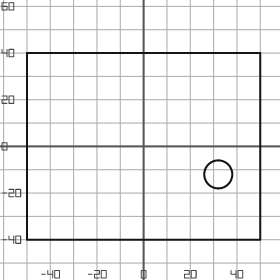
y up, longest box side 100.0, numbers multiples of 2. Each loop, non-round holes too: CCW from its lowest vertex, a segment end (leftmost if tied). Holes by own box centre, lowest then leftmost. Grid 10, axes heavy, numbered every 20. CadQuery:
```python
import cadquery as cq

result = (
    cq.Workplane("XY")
    .moveTo(-50.0, -40.0)
    .lineTo(50.0, -40.0)
    .lineTo(50.0, 40.0)
    .lineTo(-50.0, 40.0)
    .close()
    .moveTo(32.0, -12.0)
    .circle(6.0)
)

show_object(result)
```